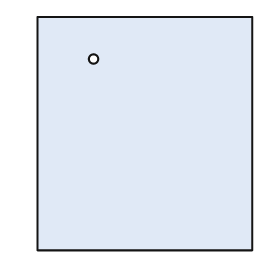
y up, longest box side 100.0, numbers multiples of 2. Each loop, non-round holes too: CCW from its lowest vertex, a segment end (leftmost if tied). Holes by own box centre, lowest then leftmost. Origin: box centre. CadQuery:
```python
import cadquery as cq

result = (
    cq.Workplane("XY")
    .moveTo(-46.0, -50.0)
    .lineTo(46.0, -50.0)
    .lineTo(46.0, 50.0)
    .lineTo(-46.0, 50.0)
    .close()
    .moveTo(-22.0, 32.0)
    .circle(2.0)
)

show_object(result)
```